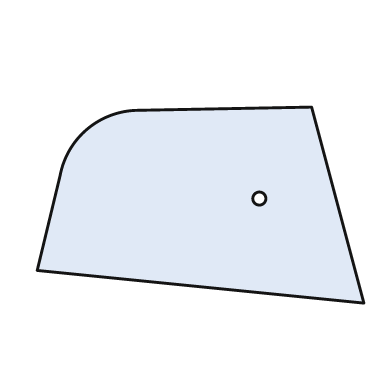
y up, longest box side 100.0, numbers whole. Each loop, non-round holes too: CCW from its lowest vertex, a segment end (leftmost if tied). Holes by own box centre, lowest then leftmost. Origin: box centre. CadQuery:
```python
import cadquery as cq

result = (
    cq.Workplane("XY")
    .moveTo(50.0, -30.0)
    .lineTo(34.0, 30.0)
    .lineTo(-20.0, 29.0)
    .threePointArc((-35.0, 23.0), (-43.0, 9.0))
    .lineTo(-50.0, -20.0)
    .close()
    .moveTo(18.0, 2.0)
    .circle(2.0)
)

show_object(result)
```